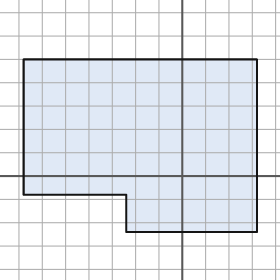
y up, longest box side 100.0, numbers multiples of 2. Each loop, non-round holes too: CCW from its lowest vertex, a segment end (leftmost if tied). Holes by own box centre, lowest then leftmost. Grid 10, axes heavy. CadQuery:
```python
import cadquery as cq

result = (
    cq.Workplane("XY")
    .moveTo(-24.0, -24.0)
    .lineTo(32.0, -24.0)
    .lineTo(32.0, 50.0)
    .lineTo(-68.0, 50.0)
    .lineTo(-68.0, -8.0)
    .lineTo(-24.0, -8.0)
    .close()
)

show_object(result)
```